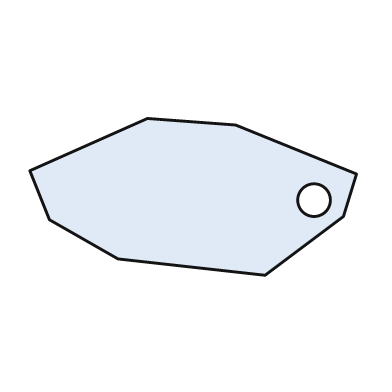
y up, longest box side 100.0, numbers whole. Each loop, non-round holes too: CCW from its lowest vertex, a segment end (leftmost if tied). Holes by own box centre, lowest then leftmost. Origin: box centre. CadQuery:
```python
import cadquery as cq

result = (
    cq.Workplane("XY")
    .moveTo(22.0, -24.0)
    .lineTo(46.0, -6.0)
    .lineTo(50.0, 7.0)
    .lineTo(13.0, 22.0)
    .lineTo(-14.0, 24.0)
    .lineTo(-50.0, 8.0)
    .lineTo(-44.0, -7.0)
    .lineTo(-23.0, -19.0)
    .close()
    .moveTo(37.0, -1.0)
    .circle(5.0)
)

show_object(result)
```